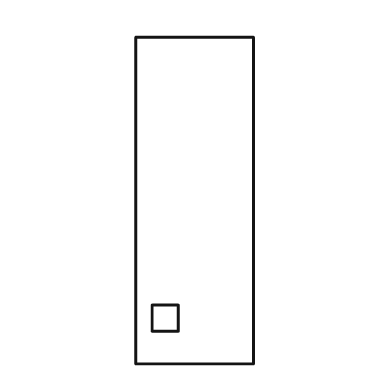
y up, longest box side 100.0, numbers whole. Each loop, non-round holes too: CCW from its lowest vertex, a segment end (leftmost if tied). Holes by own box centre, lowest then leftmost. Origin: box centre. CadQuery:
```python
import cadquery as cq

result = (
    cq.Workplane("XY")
    .moveTo(-18.0, -50.0)
    .lineTo(18.0, -50.0)
    .lineTo(18.0, 50.0)
    .lineTo(-18.0, 50.0)
    .close()
    .moveTo(-13.0, -40.0)
    .lineTo(-5.0, -40.0)
    .lineTo(-5.0, -32.0)
    .lineTo(-13.0, -32.0)
    .close()
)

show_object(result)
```